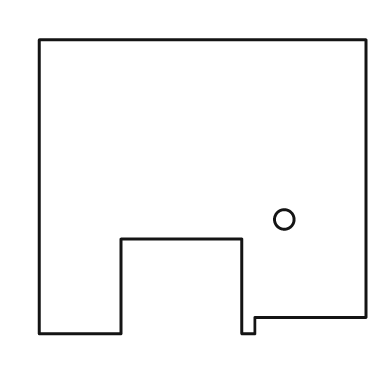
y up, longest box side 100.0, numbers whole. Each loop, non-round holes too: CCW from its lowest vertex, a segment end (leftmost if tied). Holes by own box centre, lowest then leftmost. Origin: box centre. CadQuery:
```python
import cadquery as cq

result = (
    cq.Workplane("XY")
    .moveTo(-50.0, -45.0)
    .lineTo(-25.0, -45.0)
    .lineTo(-25.0, -16.0)
    .lineTo(12.0, -16.0)
    .lineTo(12.0, -45.0)
    .lineTo(16.0, -45.0)
    .lineTo(16.0, -40.0)
    .lineTo(50.0, -40.0)
    .lineTo(50.0, 45.0)
    .lineTo(-50.0, 45.0)
    .close()
    .moveTo(25.0, -10.0)
    .circle(3.0)
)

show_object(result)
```